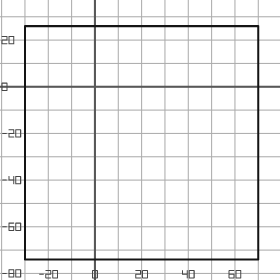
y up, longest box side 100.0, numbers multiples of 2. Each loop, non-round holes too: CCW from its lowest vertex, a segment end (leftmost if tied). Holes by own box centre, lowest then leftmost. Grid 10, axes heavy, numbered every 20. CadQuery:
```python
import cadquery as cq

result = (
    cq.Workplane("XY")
    .moveTo(-30.0, -74.0)
    .lineTo(70.0, -74.0)
    .lineTo(70.0, 26.0)
    .lineTo(-30.0, 26.0)
    .close()
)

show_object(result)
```